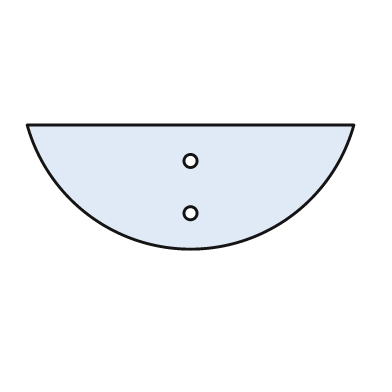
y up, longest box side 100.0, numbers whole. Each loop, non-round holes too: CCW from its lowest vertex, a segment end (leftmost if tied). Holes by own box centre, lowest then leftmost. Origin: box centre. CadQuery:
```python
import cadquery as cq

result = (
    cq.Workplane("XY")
    .moveTo(-50.0, 19.0)
    .threePointArc((0.0, -19.0), (50.0, 19.0))
    .close()
    .moveTo(0.0, -8.0)
    .circle(2.0)
    .moveTo(0.0, 8.0)
    .circle(2.0)
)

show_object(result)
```